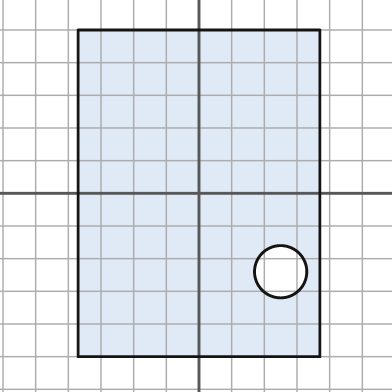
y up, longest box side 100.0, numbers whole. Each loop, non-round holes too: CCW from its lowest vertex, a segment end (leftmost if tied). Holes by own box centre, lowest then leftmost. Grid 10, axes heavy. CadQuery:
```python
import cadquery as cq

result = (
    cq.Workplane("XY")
    .moveTo(-37.0, -50.0)
    .lineTo(37.0, -50.0)
    .lineTo(37.0, 50.0)
    .lineTo(-37.0, 50.0)
    .close()
    .moveTo(25.0, -24.0)
    .circle(8.0)
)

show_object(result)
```